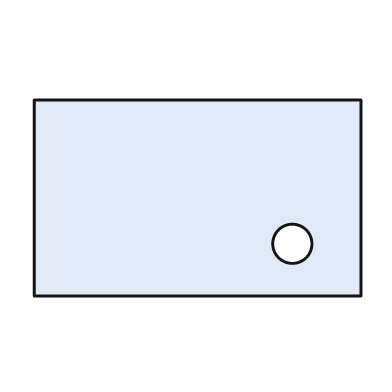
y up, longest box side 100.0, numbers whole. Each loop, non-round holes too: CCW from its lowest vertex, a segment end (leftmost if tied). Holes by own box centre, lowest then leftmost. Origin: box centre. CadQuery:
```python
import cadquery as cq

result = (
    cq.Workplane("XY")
    .moveTo(-50.0, -30.0)
    .lineTo(50.0, -30.0)
    .lineTo(50.0, 30.0)
    .lineTo(-50.0, 30.0)
    .close()
    .moveTo(29.0, -14.0)
    .circle(6.0)
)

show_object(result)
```